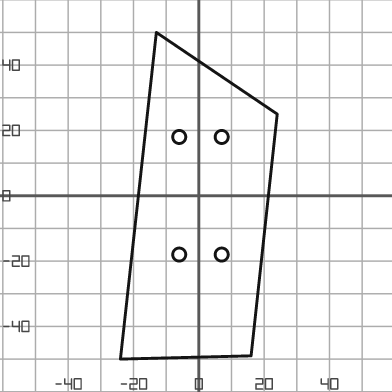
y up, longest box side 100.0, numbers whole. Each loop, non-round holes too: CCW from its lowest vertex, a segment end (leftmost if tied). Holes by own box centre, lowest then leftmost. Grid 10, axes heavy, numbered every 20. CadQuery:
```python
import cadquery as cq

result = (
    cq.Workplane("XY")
    .moveTo(-24.0, -50.0)
    .lineTo(16.0, -49.0)
    .lineTo(24.0, 25.0)
    .lineTo(-13.0, 50.0)
    .close()
    .moveTo(-6.0, -18.0)
    .circle(2.0)
    .moveTo(7.0, -18.0)
    .circle(2.0)
    .moveTo(-6.0, 18.0)
    .circle(2.0)
    .moveTo(7.0, 18.0)
    .circle(2.0)
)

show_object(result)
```